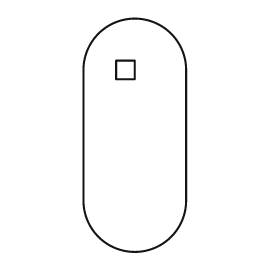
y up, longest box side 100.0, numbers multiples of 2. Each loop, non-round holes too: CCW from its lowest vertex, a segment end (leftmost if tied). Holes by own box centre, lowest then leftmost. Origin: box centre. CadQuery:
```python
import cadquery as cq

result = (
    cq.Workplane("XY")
    .moveTo(-22.0, -28.0)
    .threePointArc((0.0, -50.0), (22.0, -28.0))
    .lineTo(22.0, 28.0)
    .threePointArc((0.0, 50.0), (-22.0, 28.0))
    .close()
    .moveTo(-8.0, 24.0)
    .lineTo(0.0, 24.0)
    .lineTo(0.0, 32.0)
    .lineTo(-8.0, 32.0)
    .close()
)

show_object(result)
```